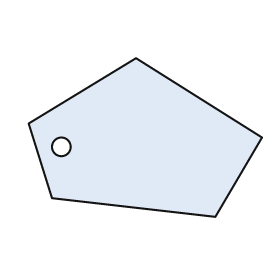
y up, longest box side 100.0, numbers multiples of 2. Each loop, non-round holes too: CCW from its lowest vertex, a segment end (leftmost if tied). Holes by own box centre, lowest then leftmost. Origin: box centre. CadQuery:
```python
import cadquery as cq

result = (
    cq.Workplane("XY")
    .moveTo(30.0, -34.0)
    .lineTo(50.0, 0.0)
    .lineTo(-4.0, 34.0)
    .lineTo(-50.0, 6.0)
    .lineTo(-40.0, -26.0)
    .close()
    .moveTo(-36.0, -4.0)
    .circle(4.0)
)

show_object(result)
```